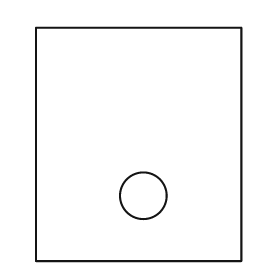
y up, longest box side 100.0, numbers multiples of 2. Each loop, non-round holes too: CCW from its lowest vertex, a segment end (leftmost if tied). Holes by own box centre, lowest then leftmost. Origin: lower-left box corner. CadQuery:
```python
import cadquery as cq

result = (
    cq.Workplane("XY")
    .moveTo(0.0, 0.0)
    .lineTo(88.0, 0.0)
    .lineTo(88.0, 100.0)
    .lineTo(0.0, 100.0)
    .close()
    .moveTo(46.0, 28.0)
    .circle(10.0)
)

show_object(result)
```